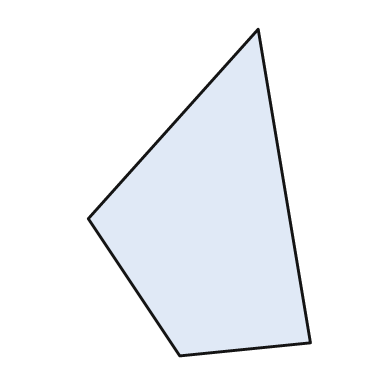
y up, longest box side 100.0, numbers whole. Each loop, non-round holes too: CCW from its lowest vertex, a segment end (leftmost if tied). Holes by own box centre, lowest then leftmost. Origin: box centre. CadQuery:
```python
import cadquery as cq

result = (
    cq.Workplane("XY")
    .moveTo(-6.0, -50.0)
    .lineTo(34.0, -46.0)
    .lineTo(18.0, 50.0)
    .lineTo(-34.0, -8.0)
    .close()
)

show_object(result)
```